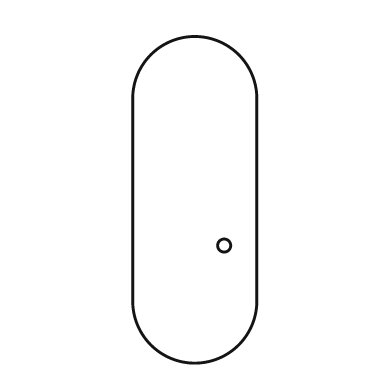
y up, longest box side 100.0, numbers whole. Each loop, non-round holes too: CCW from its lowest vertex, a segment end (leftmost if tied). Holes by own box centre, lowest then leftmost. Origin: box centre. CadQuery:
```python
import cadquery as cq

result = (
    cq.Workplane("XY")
    .moveTo(-19.0, -31.0)
    .threePointArc((0.0, -50.0), (19.0, -31.0))
    .lineTo(19.0, 31.0)
    .threePointArc((0.0, 50.0), (-19.0, 31.0))
    .close()
    .moveTo(9.0, -14.0)
    .circle(2.0)
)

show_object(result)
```